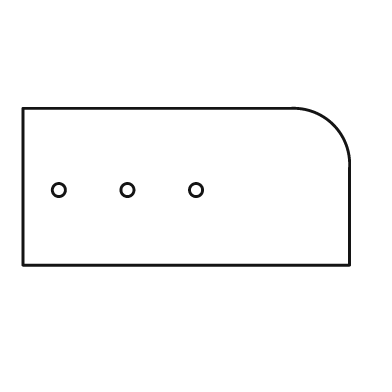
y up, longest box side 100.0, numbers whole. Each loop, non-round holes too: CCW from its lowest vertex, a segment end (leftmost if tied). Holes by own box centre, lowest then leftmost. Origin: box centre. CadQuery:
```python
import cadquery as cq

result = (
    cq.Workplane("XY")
    .moveTo(-50.0, -24.0)
    .lineTo(50.0, -24.0)
    .lineTo(50.0, 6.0)
    .threePointArc((45.0, 19.0), (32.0, 24.0))
    .lineTo(-50.0, 24.0)
    .close()
    .moveTo(-39.0, -1.0)
    .circle(2.0)
    .moveTo(-18.0, -1.0)
    .circle(2.0)
    .moveTo(3.0, -1.0)
    .circle(2.0)
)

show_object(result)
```